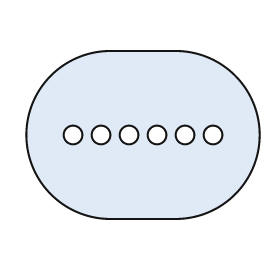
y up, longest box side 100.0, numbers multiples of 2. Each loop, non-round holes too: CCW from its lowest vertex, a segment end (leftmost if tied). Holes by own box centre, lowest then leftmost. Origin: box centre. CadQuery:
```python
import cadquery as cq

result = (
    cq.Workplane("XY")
    .moveTo(-14.0, -36.0)
    .lineTo(14.0, -36.0)
    .threePointArc((50.0, 0.0), (14.0, 36.0))
    .lineTo(-14.0, 36.0)
    .threePointArc((-50.0, 0.0), (-14.0, -36.0))
    .close()
    .moveTo(-30.0, 0.0)
    .circle(4.0)
    .moveTo(-18.0, 0.0)
    .circle(4.0)
    .moveTo(-6.0, 0.0)
    .circle(4.0)
    .moveTo(6.0, 0.0)
    .circle(4.0)
    .moveTo(18.0, 0.0)
    .circle(4.0)
    .moveTo(30.0, 0.0)
    .circle(4.0)
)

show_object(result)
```